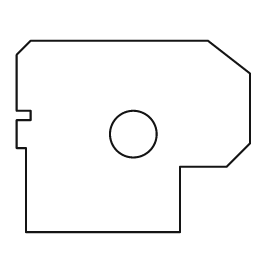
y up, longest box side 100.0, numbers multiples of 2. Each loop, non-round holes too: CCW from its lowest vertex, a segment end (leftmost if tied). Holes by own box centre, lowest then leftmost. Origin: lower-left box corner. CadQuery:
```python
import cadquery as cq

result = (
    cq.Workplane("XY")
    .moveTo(4.0, 0.0)
    .lineTo(70.0, 0.0)
    .lineTo(70.0, 28.0)
    .lineTo(90.0, 28.0)
    .lineTo(100.0, 38.0)
    .lineTo(100.0, 68.0)
    .lineTo(82.0, 82.0)
    .lineTo(6.0, 82.0)
    .lineTo(0.0, 76.0)
    .lineTo(0.0, 52.0)
    .lineTo(6.0, 52.0)
    .lineTo(6.0, 48.0)
    .lineTo(0.0, 48.0)
    .lineTo(0.0, 36.0)
    .lineTo(4.0, 36.0)
    .close()
    .moveTo(50.0, 42.0)
    .circle(10.0)
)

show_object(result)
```